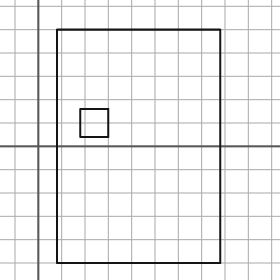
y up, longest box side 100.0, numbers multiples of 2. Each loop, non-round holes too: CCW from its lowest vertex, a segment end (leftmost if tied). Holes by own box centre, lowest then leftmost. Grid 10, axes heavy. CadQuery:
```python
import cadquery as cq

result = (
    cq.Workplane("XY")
    .moveTo(8.0, -50.0)
    .lineTo(78.0, -50.0)
    .lineTo(78.0, 50.0)
    .lineTo(8.0, 50.0)
    .close()
    .moveTo(18.0, 4.0)
    .lineTo(30.0, 4.0)
    .lineTo(30.0, 16.0)
    .lineTo(18.0, 16.0)
    .close()
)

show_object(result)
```